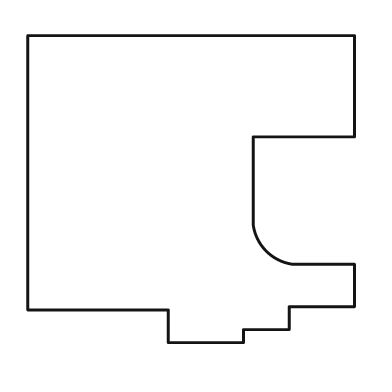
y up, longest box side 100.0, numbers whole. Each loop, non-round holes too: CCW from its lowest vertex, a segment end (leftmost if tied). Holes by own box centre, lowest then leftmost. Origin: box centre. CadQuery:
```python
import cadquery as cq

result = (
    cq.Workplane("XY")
    .moveTo(-7.0, -47.0)
    .lineTo(16.0, -47.0)
    .lineTo(16.0, -43.0)
    .lineTo(30.0, -43.0)
    .lineTo(30.0, -36.0)
    .lineTo(50.0, -36.0)
    .lineTo(50.0, -23.0)
    .lineTo(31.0, -23.0)
    .threePointArc((23.0, -19.0), (19.0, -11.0))
    .lineTo(19.0, 16.0)
    .lineTo(50.0, 16.0)
    .lineTo(50.0, 47.0)
    .lineTo(-50.0, 47.0)
    .lineTo(-50.0, -37.0)
    .lineTo(-7.0, -37.0)
    .close()
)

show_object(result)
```